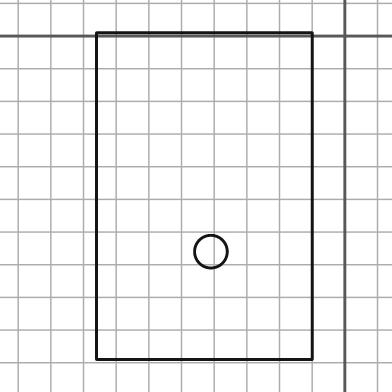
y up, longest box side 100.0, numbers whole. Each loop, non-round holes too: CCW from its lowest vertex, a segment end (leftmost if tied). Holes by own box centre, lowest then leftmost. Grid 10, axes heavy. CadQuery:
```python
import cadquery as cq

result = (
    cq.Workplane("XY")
    .moveTo(-76.0, -99.0)
    .lineTo(-10.0, -99.0)
    .lineTo(-10.0, 1.0)
    .lineTo(-76.0, 1.0)
    .close()
    .moveTo(-41.0, -66.0)
    .circle(5.0)
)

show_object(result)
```